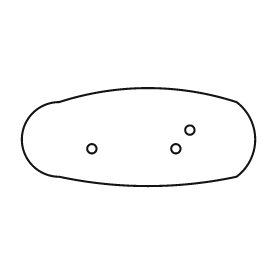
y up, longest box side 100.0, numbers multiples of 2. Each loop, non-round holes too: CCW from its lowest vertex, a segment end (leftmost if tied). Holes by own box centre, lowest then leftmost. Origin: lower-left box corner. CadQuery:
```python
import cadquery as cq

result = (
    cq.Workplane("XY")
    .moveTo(16.0, 4.0)
    .threePointArc((54.0, 0.0), (92.0, 4.0))
    .threePointArc((100.0, 20.0), (92.0, 36.0))
    .threePointArc((54.0, 42.0), (16.0, 36.0))
    .threePointArc((0.0, 20.0), (16.0, 4.0))
    .close()
    .moveTo(30.0, 16.0)
    .circle(2.0)
    .moveTo(66.0, 16.0)
    .circle(2.0)
    .moveTo(72.0, 24.0)
    .circle(2.0)
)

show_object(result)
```